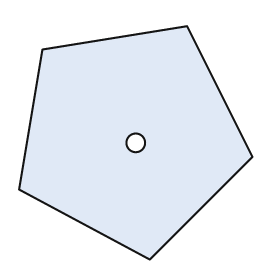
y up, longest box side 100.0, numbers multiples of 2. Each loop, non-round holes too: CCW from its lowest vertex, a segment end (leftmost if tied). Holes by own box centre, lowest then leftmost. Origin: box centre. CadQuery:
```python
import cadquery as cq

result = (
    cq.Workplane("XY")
    .moveTo(6.0, -50.0)
    .lineTo(50.0, -6.0)
    .lineTo(22.0, 50.0)
    .lineTo(-40.0, 40.0)
    .lineTo(-50.0, -20.0)
    .close()
    .moveTo(0.0, 0.0)
    .circle(4.0)
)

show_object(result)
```